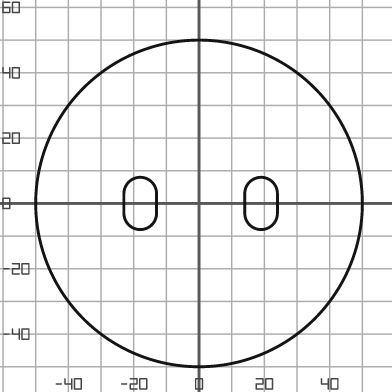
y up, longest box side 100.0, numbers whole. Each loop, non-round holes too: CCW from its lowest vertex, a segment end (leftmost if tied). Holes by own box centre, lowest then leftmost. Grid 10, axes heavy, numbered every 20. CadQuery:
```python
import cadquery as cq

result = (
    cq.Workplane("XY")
    .moveTo(0.0, 0.0)
    .circle(50.0)
    .moveTo(-23.0, -3.0)
    .threePointArc((-18.0, -8.0), (-13.0, -3.0))
    .lineTo(-13.0, 3.0)
    .threePointArc((-18.0, 8.0), (-23.0, 3.0))
    .close()
    .moveTo(14.0, -3.0)
    .threePointArc((19.0, -8.0), (24.0, -3.0))
    .lineTo(24.0, 3.0)
    .threePointArc((19.0, 8.0), (14.0, 3.0))
    .close()
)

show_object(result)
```